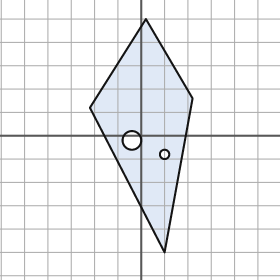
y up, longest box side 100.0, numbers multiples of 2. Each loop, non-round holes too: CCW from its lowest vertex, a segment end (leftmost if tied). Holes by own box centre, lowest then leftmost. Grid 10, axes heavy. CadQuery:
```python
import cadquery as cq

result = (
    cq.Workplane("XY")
    .moveTo(10.0, -50.0)
    .lineTo(22.0, 16.0)
    .lineTo(2.0, 50.0)
    .lineTo(-22.0, 12.0)
    .close()
    .moveTo(10.0, -8.0)
    .circle(2.0)
    .moveTo(-4.0, -2.0)
    .circle(4.0)
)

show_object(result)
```